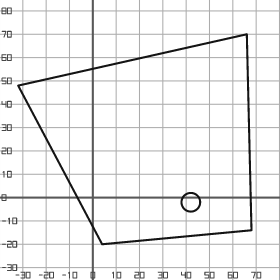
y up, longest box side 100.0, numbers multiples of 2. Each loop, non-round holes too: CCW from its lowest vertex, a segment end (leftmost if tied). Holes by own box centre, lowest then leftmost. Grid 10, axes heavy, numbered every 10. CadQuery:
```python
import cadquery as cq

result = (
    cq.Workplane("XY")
    .moveTo(4.0, -20.0)
    .lineTo(68.0, -14.0)
    .lineTo(66.0, 70.0)
    .lineTo(-32.0, 48.0)
    .close()
    .moveTo(42.0, -2.0)
    .circle(4.0)
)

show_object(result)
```